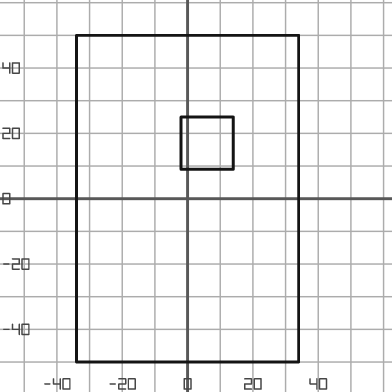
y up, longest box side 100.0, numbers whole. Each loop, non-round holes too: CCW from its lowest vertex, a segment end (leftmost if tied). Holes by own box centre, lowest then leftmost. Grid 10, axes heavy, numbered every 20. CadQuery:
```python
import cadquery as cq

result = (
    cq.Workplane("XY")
    .moveTo(-34.0, -50.0)
    .lineTo(34.0, -50.0)
    .lineTo(34.0, 50.0)
    .lineTo(-34.0, 50.0)
    .close()
    .moveTo(-2.0, 9.0)
    .lineTo(14.0, 9.0)
    .lineTo(14.0, 25.0)
    .lineTo(-2.0, 25.0)
    .close()
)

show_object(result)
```